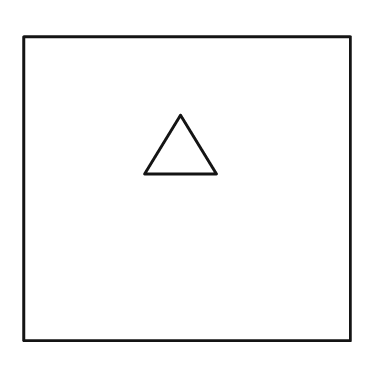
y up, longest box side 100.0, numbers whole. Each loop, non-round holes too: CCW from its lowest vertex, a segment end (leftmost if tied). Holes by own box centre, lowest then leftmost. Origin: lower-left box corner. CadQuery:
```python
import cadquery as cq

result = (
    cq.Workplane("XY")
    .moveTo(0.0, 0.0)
    .lineTo(100.0, 0.0)
    .lineTo(100.0, 93.0)
    .lineTo(0.0, 93.0)
    .close()
    .moveTo(37.0, 51.0)
    .lineTo(59.0, 51.0)
    .lineTo(48.0, 69.0)
    .close()
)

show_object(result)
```